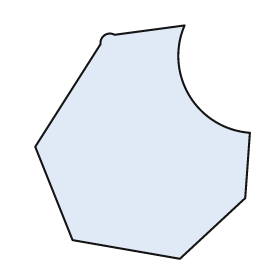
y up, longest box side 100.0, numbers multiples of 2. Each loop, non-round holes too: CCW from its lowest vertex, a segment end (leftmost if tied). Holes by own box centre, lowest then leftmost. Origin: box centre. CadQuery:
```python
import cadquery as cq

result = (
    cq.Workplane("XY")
    .moveTo(16.0, -50.0)
    .lineTo(44.0, -24.0)
    .lineTo(46.0, 4.0)
    .threePointArc((20.0, 20.0), (18.0, 50.0))
    .lineTo(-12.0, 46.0)
    .threePointArc((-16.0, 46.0), (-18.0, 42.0))
    .lineTo(-46.0, -2.0)
    .lineTo(-30.0, -42.0)
    .close()
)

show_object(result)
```